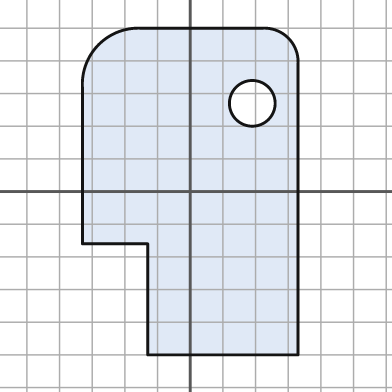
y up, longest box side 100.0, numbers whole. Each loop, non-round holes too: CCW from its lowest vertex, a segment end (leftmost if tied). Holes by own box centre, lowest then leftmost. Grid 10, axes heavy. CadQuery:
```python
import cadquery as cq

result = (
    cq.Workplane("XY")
    .moveTo(-13.0, -50.0)
    .lineTo(33.0, -50.0)
    .lineTo(33.0, 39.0)
    .threePointArc((30.0, 47.0), (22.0, 50.0))
    .lineTo(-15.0, 50.0)
    .threePointArc((-28.0, 45.0), (-33.0, 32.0))
    .lineTo(-33.0, -16.0)
    .lineTo(-13.0, -16.0)
    .close()
    .moveTo(19.0, 27.0)
    .circle(7.0)
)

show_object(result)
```